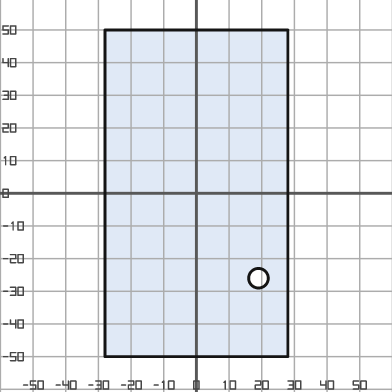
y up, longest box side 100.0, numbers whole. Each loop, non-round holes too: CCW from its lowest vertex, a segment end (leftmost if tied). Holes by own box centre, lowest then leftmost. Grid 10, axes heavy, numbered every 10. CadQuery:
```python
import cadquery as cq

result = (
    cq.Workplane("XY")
    .moveTo(-28.0, -50.0)
    .lineTo(28.0, -50.0)
    .lineTo(28.0, 50.0)
    .lineTo(-28.0, 50.0)
    .close()
    .moveTo(19.0, -26.0)
    .circle(3.0)
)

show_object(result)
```